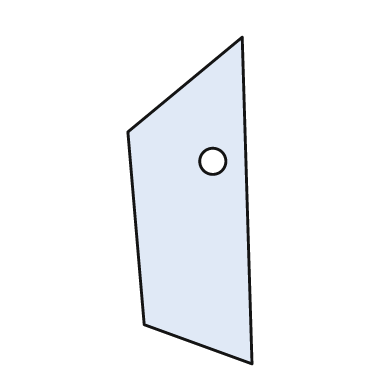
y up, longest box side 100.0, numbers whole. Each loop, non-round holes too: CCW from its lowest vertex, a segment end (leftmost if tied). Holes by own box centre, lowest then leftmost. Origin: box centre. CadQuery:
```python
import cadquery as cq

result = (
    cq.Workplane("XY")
    .moveTo(19.0, -50.0)
    .lineTo(16.0, 50.0)
    .lineTo(-19.0, 21.0)
    .lineTo(-14.0, -38.0)
    .close()
    .moveTo(7.0, 12.0)
    .circle(4.0)
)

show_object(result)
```